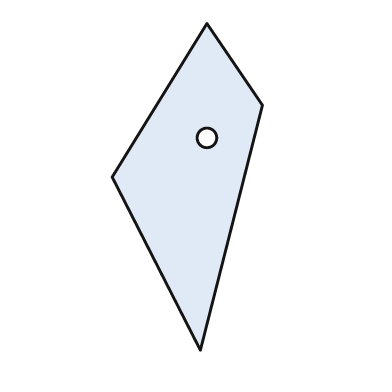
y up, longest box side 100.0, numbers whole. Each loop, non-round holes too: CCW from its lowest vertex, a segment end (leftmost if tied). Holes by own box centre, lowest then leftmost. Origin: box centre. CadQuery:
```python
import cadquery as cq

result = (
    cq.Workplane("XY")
    .moveTo(4.0, -50.0)
    .lineTo(23.0, 25.0)
    .lineTo(6.0, 50.0)
    .lineTo(-23.0, 3.0)
    .close()
    .moveTo(6.0, 15.0)
    .circle(3.0)
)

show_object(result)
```